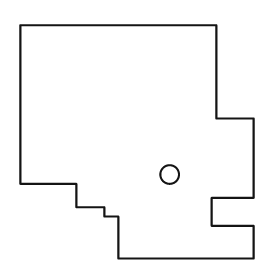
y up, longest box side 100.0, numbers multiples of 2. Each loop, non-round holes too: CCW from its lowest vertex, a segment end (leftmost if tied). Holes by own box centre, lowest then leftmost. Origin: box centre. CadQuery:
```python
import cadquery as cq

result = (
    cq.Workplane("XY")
    .moveTo(-8.0, -50.0)
    .lineTo(50.0, -50.0)
    .lineTo(50.0, -36.0)
    .lineTo(32.0, -36.0)
    .lineTo(32.0, -24.0)
    .lineTo(50.0, -24.0)
    .lineTo(50.0, 10.0)
    .lineTo(34.0, 10.0)
    .lineTo(34.0, 50.0)
    .lineTo(-50.0, 50.0)
    .lineTo(-50.0, -18.0)
    .lineTo(-26.0, -18.0)
    .lineTo(-26.0, -28.0)
    .lineTo(-14.0, -28.0)
    .lineTo(-14.0, -32.0)
    .lineTo(-8.0, -32.0)
    .close()
    .moveTo(14.0, -14.0)
    .circle(4.0)
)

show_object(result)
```